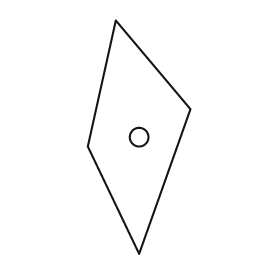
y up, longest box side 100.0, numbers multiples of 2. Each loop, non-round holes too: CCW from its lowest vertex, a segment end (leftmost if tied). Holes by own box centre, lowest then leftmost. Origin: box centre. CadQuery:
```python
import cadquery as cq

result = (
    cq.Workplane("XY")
    .moveTo(0.0, -50.0)
    .lineTo(22.0, 12.0)
    .lineTo(-10.0, 50.0)
    .lineTo(-22.0, -4.0)
    .close()
    .moveTo(0.0, 0.0)
    .circle(4.0)
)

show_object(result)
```